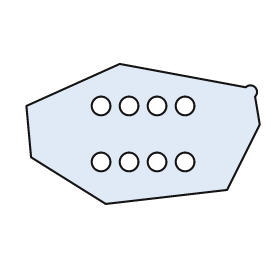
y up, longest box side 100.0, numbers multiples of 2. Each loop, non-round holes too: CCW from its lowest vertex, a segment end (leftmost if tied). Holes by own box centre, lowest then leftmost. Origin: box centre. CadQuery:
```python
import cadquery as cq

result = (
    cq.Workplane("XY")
    .moveTo(-16.0, -30.0)
    .lineTo(36.0, -24.0)
    .lineTo(50.0, 4.0)
    .lineTo(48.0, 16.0)
    .threePointArc((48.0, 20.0), (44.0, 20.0))
    .lineTo(-10.0, 30.0)
    .lineTo(-50.0, 12.0)
    .lineTo(-48.0, -10.0)
    .close()
    .moveTo(-18.0, -12.0)
    .circle(4.0)
    .moveTo(-6.0, -12.0)
    .circle(4.0)
    .moveTo(6.0, -12.0)
    .circle(4.0)
    .moveTo(18.0, -12.0)
    .circle(4.0)
    .moveTo(-18.0, 12.0)
    .circle(4.0)
    .moveTo(-6.0, 12.0)
    .circle(4.0)
    .moveTo(6.0, 12.0)
    .circle(4.0)
    .moveTo(18.0, 12.0)
    .circle(4.0)
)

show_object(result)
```